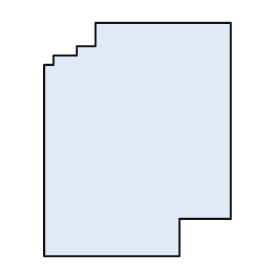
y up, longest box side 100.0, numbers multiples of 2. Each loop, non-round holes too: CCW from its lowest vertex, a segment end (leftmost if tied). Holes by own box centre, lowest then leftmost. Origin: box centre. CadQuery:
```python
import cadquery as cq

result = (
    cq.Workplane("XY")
    .moveTo(-40.0, -50.0)
    .lineTo(18.0, -50.0)
    .lineTo(18.0, -34.0)
    .lineTo(40.0, -34.0)
    .lineTo(40.0, 50.0)
    .lineTo(-18.0, 50.0)
    .lineTo(-18.0, 40.0)
    .lineTo(-26.0, 40.0)
    .lineTo(-26.0, 36.0)
    .lineTo(-36.0, 36.0)
    .lineTo(-36.0, 32.0)
    .lineTo(-40.0, 32.0)
    .close()
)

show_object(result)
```